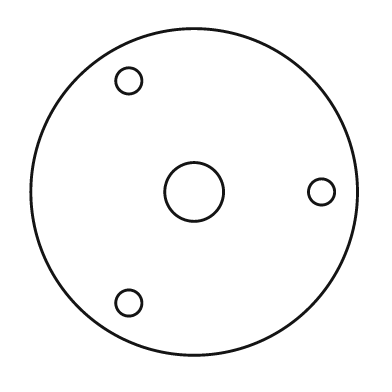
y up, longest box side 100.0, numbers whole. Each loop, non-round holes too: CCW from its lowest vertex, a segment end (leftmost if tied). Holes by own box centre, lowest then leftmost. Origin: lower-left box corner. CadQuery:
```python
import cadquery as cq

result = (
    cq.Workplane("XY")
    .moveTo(50.0, 50.0)
    .circle(50.0)
    .moveTo(30.0, 16.0)
    .circle(4.0)
    .moveTo(50.0, 50.0)
    .circle(9.0)
    .moveTo(89.0, 50.0)
    .circle(4.0)
    .moveTo(30.0, 84.0)
    .circle(4.0)
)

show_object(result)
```